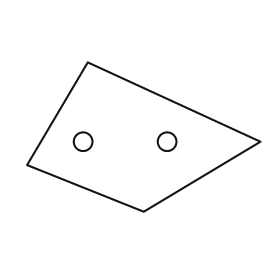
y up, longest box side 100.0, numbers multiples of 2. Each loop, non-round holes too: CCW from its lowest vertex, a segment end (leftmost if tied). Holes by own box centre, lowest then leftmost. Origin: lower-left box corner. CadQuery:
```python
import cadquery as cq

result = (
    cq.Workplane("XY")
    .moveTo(50.0, 0.0)
    .lineTo(100.0, 30.0)
    .lineTo(26.0, 64.0)
    .lineTo(0.0, 20.0)
    .close()
    .moveTo(24.0, 30.0)
    .circle(4.0)
    .moveTo(60.0, 30.0)
    .circle(4.0)
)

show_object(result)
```